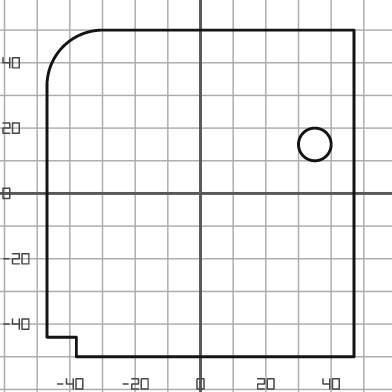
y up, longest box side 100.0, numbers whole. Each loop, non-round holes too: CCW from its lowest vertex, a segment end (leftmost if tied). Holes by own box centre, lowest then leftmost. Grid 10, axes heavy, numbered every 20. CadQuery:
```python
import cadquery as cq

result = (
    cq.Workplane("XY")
    .moveTo(-38.0, -50.0)
    .lineTo(47.0, -50.0)
    .lineTo(47.0, 50.0)
    .lineTo(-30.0, 50.0)
    .threePointArc((-42.0, 45.0), (-47.0, 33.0))
    .lineTo(-47.0, -44.0)
    .lineTo(-38.0, -44.0)
    .close()
    .moveTo(35.0, 15.0)
    .circle(5.0)
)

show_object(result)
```